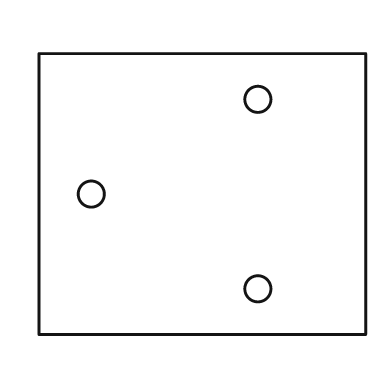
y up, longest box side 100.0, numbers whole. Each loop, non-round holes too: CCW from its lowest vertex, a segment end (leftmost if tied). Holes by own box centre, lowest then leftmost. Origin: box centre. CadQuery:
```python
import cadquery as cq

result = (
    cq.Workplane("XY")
    .moveTo(-50.0, -43.0)
    .lineTo(50.0, -43.0)
    .lineTo(50.0, 43.0)
    .lineTo(-50.0, 43.0)
    .close()
    .moveTo(17.0, -29.0)
    .circle(4.0)
    .moveTo(-34.0, 0.0)
    .circle(4.0)
    .moveTo(17.0, 29.0)
    .circle(4.0)
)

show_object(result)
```